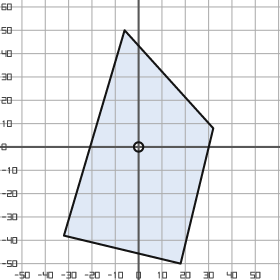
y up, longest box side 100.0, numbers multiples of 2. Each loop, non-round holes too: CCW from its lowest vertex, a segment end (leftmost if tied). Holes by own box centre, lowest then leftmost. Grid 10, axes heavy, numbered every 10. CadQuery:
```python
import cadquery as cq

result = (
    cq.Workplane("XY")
    .moveTo(18.0, -50.0)
    .lineTo(32.0, 8.0)
    .lineTo(-6.0, 50.0)
    .lineTo(-32.0, -38.0)
    .close()
    .moveTo(0.0, 0.0)
    .circle(2.0)
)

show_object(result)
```